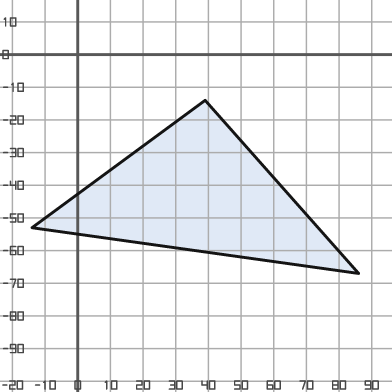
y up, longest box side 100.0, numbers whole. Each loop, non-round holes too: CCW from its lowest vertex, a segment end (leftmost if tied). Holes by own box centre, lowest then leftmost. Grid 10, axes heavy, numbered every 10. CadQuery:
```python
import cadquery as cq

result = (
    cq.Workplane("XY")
    .moveTo(86.0, -67.0)
    .lineTo(39.0, -14.0)
    .lineTo(-14.0, -53.0)
    .close()
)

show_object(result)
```